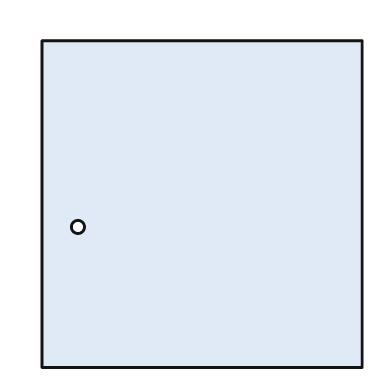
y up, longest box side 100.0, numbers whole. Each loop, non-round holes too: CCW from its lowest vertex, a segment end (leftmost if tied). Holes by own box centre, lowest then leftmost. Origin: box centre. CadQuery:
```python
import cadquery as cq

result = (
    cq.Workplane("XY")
    .moveTo(-49.0, -50.0)
    .lineTo(49.0, -50.0)
    .lineTo(49.0, 50.0)
    .lineTo(-49.0, 50.0)
    .close()
    .moveTo(-38.0, -7.0)
    .circle(2.0)
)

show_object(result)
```